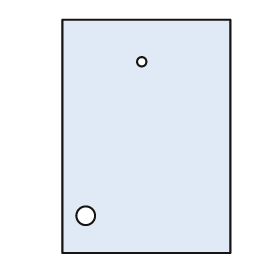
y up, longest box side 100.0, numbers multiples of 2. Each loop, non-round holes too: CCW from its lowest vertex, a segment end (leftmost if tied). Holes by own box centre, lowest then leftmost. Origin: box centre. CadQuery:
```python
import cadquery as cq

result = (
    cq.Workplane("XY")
    .moveTo(-36.0, -50.0)
    .lineTo(36.0, -50.0)
    .lineTo(36.0, 50.0)
    .lineTo(-36.0, 50.0)
    .close()
    .moveTo(-26.0, -34.0)
    .circle(4.0)
    .moveTo(-2.0, 32.0)
    .circle(2.0)
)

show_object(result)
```